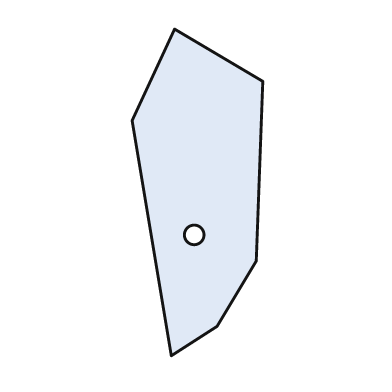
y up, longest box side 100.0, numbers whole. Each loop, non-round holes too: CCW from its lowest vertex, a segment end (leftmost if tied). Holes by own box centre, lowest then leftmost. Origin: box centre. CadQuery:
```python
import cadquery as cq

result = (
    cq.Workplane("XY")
    .moveTo(-8.0, -50.0)
    .lineTo(6.0, -41.0)
    .lineTo(18.0, -21.0)
    .lineTo(20.0, 34.0)
    .lineTo(-7.0, 50.0)
    .lineTo(-20.0, 22.0)
    .close()
    .moveTo(-1.0, -13.0)
    .circle(3.0)
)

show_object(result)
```